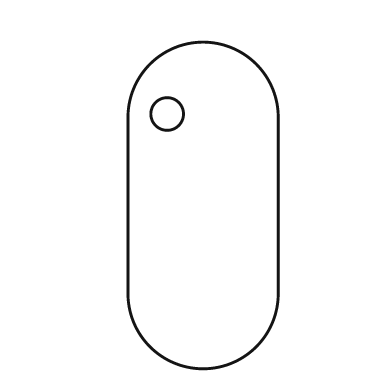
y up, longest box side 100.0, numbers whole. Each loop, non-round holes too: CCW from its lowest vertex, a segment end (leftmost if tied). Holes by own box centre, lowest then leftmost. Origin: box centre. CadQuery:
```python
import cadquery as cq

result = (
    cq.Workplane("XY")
    .moveTo(-23.0, -27.0)
    .threePointArc((0.0, -50.0), (23.0, -27.0))
    .lineTo(23.0, 27.0)
    .threePointArc((0.0, 50.0), (-23.0, 27.0))
    .close()
    .moveTo(-11.0, 28.0)
    .circle(5.0)
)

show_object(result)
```